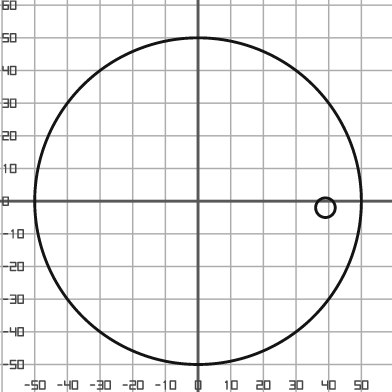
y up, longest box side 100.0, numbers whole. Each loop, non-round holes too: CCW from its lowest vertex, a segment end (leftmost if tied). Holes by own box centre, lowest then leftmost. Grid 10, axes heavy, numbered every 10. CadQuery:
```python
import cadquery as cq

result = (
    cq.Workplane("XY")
    .moveTo(0.0, 0.0)
    .circle(50.0)
    .moveTo(39.0, -2.0)
    .circle(3.0)
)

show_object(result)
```